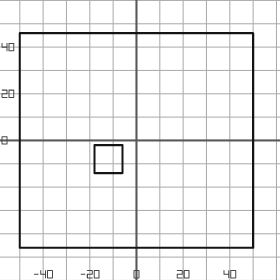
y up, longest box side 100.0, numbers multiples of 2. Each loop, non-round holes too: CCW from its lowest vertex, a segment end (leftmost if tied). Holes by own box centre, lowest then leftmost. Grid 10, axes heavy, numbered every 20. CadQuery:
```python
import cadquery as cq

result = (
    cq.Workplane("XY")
    .moveTo(-50.0, -46.0)
    .lineTo(50.0, -46.0)
    .lineTo(50.0, 46.0)
    .lineTo(-50.0, 46.0)
    .close()
    .moveTo(-18.0, -14.0)
    .lineTo(-6.0, -14.0)
    .lineTo(-6.0, -2.0)
    .lineTo(-18.0, -2.0)
    .close()
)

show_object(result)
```